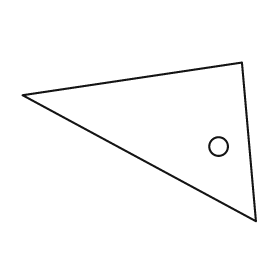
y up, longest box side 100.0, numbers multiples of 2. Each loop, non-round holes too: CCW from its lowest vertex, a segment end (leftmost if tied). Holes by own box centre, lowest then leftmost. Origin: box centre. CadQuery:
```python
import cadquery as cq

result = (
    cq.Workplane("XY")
    .moveTo(50.0, -34.0)
    .lineTo(44.0, 34.0)
    .lineTo(-50.0, 20.0)
    .close()
    .moveTo(34.0, -2.0)
    .circle(4.0)
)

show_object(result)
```